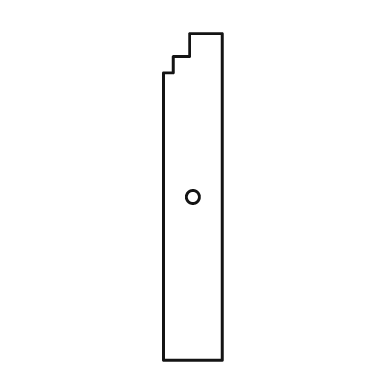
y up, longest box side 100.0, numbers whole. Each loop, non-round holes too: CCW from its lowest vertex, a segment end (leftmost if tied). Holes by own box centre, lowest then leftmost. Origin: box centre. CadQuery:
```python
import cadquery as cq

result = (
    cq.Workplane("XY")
    .moveTo(-9.0, -50.0)
    .lineTo(9.0, -50.0)
    .lineTo(9.0, 50.0)
    .lineTo(-1.0, 50.0)
    .lineTo(-1.0, 43.0)
    .lineTo(-6.0, 43.0)
    .lineTo(-6.0, 38.0)
    .lineTo(-9.0, 38.0)
    .close()
    .moveTo(0.0, 0.0)
    .circle(2.0)
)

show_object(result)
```